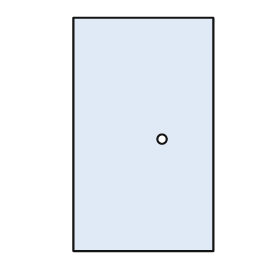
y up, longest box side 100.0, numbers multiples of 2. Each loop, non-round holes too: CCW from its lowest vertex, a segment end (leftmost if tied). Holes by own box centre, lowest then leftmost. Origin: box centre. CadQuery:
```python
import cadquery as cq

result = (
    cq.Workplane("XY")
    .moveTo(-30.0, -50.0)
    .lineTo(30.0, -50.0)
    .lineTo(30.0, 50.0)
    .lineTo(-30.0, 50.0)
    .close()
    .moveTo(8.0, -2.0)
    .circle(2.0)
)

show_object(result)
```